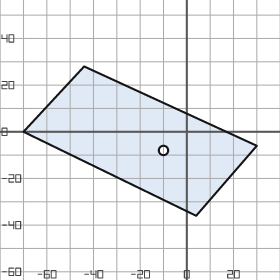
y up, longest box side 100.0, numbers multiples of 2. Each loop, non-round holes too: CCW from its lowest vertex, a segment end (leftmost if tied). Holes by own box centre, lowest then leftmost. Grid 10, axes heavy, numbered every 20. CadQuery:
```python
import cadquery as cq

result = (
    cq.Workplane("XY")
    .moveTo(4.0, -36.0)
    .lineTo(30.0, -6.0)
    .lineTo(-44.0, 28.0)
    .lineTo(-70.0, 0.0)
    .close()
    .moveTo(-10.0, -8.0)
    .circle(2.0)
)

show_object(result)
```